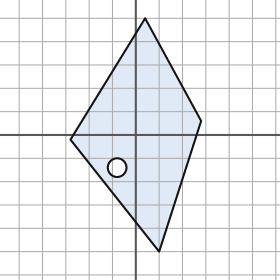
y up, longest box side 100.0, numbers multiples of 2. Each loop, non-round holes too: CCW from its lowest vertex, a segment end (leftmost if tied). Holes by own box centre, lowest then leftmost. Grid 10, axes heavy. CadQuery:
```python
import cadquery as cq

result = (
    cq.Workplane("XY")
    .moveTo(10.0, -50.0)
    .lineTo(28.0, 6.0)
    .lineTo(4.0, 50.0)
    .lineTo(-28.0, -2.0)
    .close()
    .moveTo(-8.0, -14.0)
    .circle(4.0)
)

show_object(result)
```